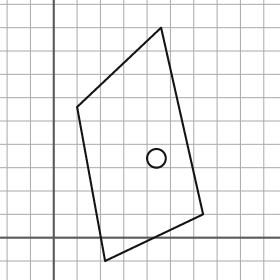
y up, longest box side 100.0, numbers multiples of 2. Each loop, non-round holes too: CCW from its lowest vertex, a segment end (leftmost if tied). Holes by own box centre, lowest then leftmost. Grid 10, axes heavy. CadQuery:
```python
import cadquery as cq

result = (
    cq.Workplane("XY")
    .moveTo(22.0, -10.0)
    .lineTo(64.0, 10.0)
    .lineTo(46.0, 90.0)
    .lineTo(10.0, 56.0)
    .close()
    .moveTo(44.0, 34.0)
    .circle(4.0)
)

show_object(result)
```